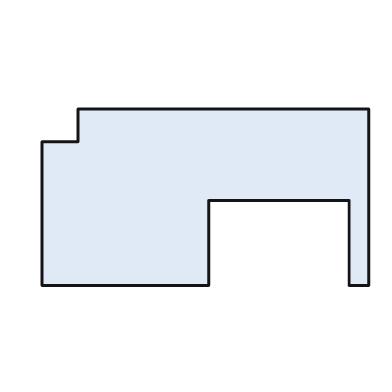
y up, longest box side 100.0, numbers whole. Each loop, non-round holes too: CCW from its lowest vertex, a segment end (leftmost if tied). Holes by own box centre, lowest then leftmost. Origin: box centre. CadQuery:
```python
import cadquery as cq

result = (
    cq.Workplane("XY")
    .moveTo(-50.0, -27.0)
    .lineTo(1.0, -27.0)
    .lineTo(1.0, -1.0)
    .lineTo(44.0, -1.0)
    .lineTo(44.0, -27.0)
    .lineTo(50.0, -27.0)
    .lineTo(50.0, 27.0)
    .lineTo(-39.0, 27.0)
    .lineTo(-39.0, 17.0)
    .lineTo(-50.0, 17.0)
    .close()
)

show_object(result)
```